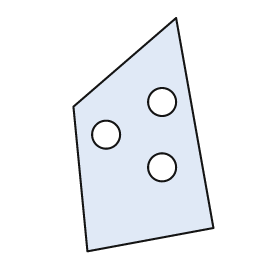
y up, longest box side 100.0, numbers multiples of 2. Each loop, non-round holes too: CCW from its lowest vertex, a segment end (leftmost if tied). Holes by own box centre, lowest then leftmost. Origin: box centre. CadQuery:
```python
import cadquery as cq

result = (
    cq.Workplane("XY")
    .moveTo(-24.0, -50.0)
    .lineTo(30.0, -40.0)
    .lineTo(14.0, 50.0)
    .lineTo(-30.0, 12.0)
    .close()
    .moveTo(8.0, -14.0)
    .circle(6.0)
    .moveTo(-16.0, 0.0)
    .circle(6.0)
    .moveTo(8.0, 14.0)
    .circle(6.0)
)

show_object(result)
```